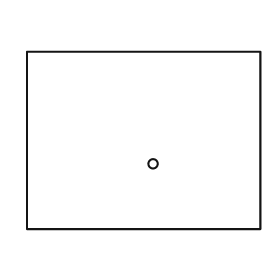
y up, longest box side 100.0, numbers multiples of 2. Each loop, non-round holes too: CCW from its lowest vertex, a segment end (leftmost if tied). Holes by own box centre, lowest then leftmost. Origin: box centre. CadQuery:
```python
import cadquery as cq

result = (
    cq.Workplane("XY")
    .moveTo(-50.0, -38.0)
    .lineTo(50.0, -38.0)
    .lineTo(50.0, 38.0)
    .lineTo(-50.0, 38.0)
    .close()
    .moveTo(4.0, -10.0)
    .circle(2.0)
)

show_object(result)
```